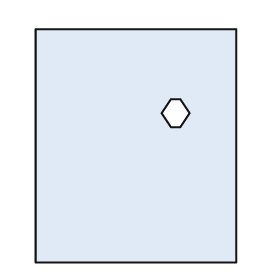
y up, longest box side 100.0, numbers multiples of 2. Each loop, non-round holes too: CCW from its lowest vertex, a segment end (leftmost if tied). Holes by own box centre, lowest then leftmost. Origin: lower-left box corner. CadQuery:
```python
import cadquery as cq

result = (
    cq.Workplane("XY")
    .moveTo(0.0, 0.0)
    .lineTo(86.0, 0.0)
    .lineTo(86.0, 100.0)
    .lineTo(0.0, 100.0)
    .close()
    .moveTo(58.0, 58.0)
    .lineTo(62.0, 58.0)
    .lineTo(66.0, 64.0)
    .lineTo(62.0, 70.0)
    .lineTo(58.0, 70.0)
    .lineTo(54.0, 64.0)
    .close()
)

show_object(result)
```